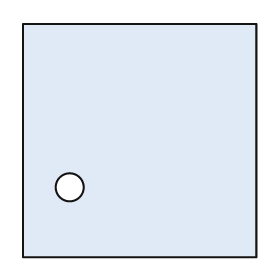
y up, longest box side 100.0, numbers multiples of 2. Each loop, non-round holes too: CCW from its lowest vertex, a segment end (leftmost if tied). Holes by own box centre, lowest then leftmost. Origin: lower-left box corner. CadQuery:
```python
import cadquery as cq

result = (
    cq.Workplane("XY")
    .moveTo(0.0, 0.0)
    .lineTo(100.0, 0.0)
    .lineTo(100.0, 100.0)
    .lineTo(0.0, 100.0)
    .close()
    .moveTo(20.0, 30.0)
    .circle(6.0)
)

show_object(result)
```